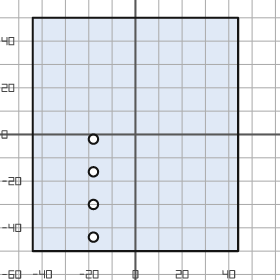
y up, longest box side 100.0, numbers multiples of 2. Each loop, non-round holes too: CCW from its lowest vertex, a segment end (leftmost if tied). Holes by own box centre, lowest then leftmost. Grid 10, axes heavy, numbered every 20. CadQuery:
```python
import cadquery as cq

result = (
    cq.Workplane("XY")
    .moveTo(-44.0, -50.0)
    .lineTo(44.0, -50.0)
    .lineTo(44.0, 50.0)
    .lineTo(-44.0, 50.0)
    .close()
    .moveTo(-18.0, -44.0)
    .circle(2.0)
    .moveTo(-18.0, -30.0)
    .circle(2.0)
    .moveTo(-18.0, -16.0)
    .circle(2.0)
    .moveTo(-18.0, -2.0)
    .circle(2.0)
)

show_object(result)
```